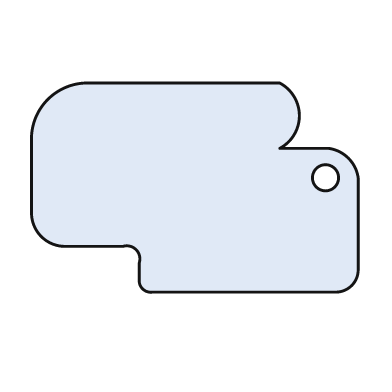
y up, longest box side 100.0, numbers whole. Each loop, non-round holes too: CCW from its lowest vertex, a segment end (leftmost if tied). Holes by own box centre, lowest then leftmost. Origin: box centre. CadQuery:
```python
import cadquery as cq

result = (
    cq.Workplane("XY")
    .moveTo(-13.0, -32.0)
    .lineTo(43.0, -32.0)
    .threePointArc((48.0, -30.0), (50.0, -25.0))
    .lineTo(50.0, 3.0)
    .threePointArc((47.0, 9.0), (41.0, 12.0))
    .lineTo(26.0, 12.0)
    .threePointArc((32.0, 22.0), (26.0, 32.0))
    .lineTo(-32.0, 32.0)
    .threePointArc((-45.0, 27.0), (-50.0, 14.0))
    .lineTo(-50.0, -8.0)
    .threePointArc((-47.0, -15.0), (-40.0, -18.0))
    .lineTo(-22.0, -18.0)
    .threePointArc((-18.0, -19.0), (-17.0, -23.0))
    .lineTo(-17.0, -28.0)
    .threePointArc((-16.0, -31.0), (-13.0, -32.0))
    .close()
    .moveTo(40.0, 3.0)
    .circle(4.0)
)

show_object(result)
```